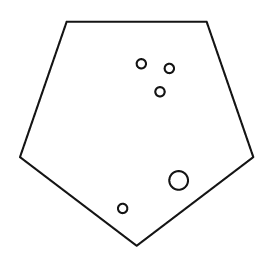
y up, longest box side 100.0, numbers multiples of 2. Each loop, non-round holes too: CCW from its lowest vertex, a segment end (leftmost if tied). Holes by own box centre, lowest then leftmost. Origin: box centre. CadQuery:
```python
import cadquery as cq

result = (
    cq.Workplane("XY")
    .moveTo(0.0, -48.0)
    .lineTo(50.0, -10.0)
    .lineTo(30.0, 48.0)
    .lineTo(-30.0, 48.0)
    .lineTo(-50.0, -10.0)
    .close()
    .moveTo(-6.0, -32.0)
    .circle(2.0)
    .moveTo(18.0, -20.0)
    .circle(4.0)
    .moveTo(10.0, 18.0)
    .circle(2.0)
    .moveTo(14.0, 28.0)
    .circle(2.0)
    .moveTo(2.0, 30.0)
    .circle(2.0)
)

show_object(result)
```